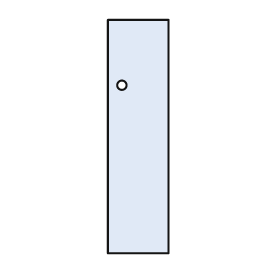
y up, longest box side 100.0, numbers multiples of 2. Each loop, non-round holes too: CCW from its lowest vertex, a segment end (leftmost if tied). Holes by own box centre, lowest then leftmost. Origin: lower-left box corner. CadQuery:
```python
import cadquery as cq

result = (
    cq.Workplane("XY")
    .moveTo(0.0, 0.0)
    .lineTo(26.0, 0.0)
    .lineTo(26.0, 100.0)
    .lineTo(0.0, 100.0)
    .close()
    .moveTo(6.0, 72.0)
    .circle(2.0)
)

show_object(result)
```